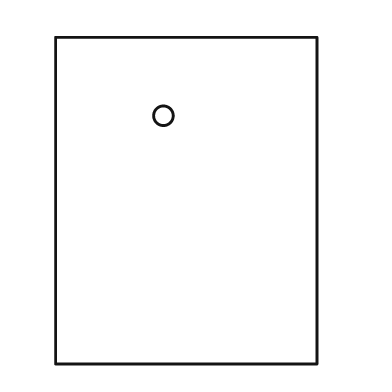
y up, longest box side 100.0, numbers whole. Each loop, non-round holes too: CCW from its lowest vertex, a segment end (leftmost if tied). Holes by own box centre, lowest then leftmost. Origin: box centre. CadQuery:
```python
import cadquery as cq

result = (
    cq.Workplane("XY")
    .moveTo(-40.0, -50.0)
    .lineTo(40.0, -50.0)
    .lineTo(40.0, 50.0)
    .lineTo(-40.0, 50.0)
    .close()
    .moveTo(-7.0, 26.0)
    .circle(3.0)
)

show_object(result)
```